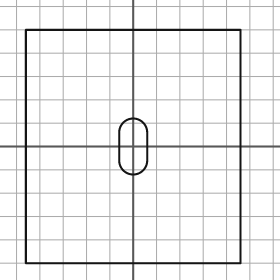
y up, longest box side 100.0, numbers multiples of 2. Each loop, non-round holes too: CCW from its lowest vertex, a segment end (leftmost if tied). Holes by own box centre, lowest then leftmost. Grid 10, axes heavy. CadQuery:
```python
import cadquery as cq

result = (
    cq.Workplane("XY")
    .moveTo(-46.0, -50.0)
    .lineTo(46.0, -50.0)
    .lineTo(46.0, 50.0)
    .lineTo(-46.0, 50.0)
    .close()
    .moveTo(-6.0, -6.0)
    .threePointArc((0.0, -12.0), (6.0, -6.0))
    .lineTo(6.0, 6.0)
    .threePointArc((0.0, 12.0), (-6.0, 6.0))
    .close()
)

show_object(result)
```